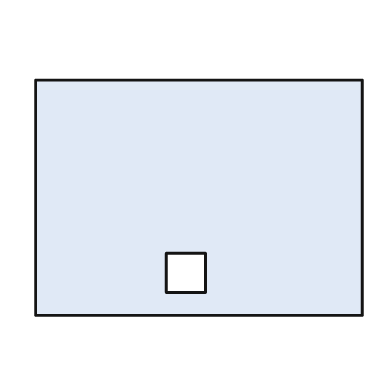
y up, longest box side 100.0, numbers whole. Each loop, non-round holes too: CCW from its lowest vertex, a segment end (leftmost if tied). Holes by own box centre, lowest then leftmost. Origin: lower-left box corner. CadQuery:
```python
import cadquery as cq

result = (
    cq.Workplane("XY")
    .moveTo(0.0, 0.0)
    .lineTo(100.0, 0.0)
    .lineTo(100.0, 72.0)
    .lineTo(0.0, 72.0)
    .close()
    .moveTo(40.0, 7.0)
    .lineTo(52.0, 7.0)
    .lineTo(52.0, 19.0)
    .lineTo(40.0, 19.0)
    .close()
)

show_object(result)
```